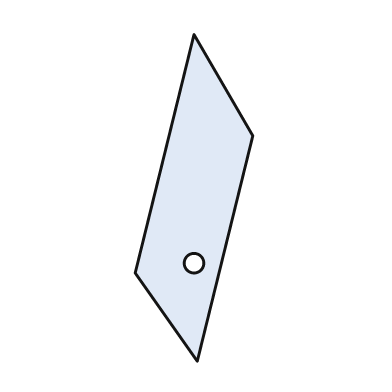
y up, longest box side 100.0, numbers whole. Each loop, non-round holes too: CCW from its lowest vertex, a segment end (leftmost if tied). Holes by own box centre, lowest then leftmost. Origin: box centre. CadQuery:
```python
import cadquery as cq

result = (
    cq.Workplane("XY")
    .moveTo(1.0, -50.0)
    .lineTo(18.0, 19.0)
    .lineTo(0.0, 50.0)
    .lineTo(-18.0, -23.0)
    .close()
    .moveTo(0.0, -20.0)
    .circle(3.0)
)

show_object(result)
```